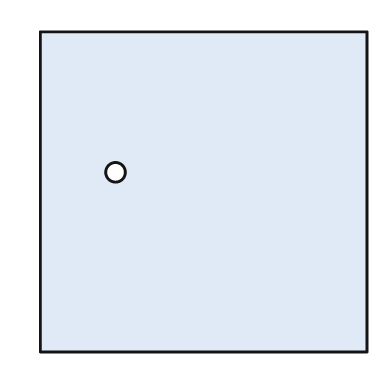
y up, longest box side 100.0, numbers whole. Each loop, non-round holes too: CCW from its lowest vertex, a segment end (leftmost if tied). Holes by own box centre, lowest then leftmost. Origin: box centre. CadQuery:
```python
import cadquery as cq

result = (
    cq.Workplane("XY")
    .moveTo(-50.0, -49.0)
    .lineTo(50.0, -49.0)
    .lineTo(50.0, 49.0)
    .lineTo(-50.0, 49.0)
    .close()
    .moveTo(-27.0, 6.0)
    .circle(3.0)
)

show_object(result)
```